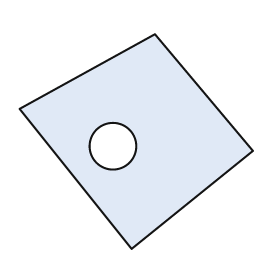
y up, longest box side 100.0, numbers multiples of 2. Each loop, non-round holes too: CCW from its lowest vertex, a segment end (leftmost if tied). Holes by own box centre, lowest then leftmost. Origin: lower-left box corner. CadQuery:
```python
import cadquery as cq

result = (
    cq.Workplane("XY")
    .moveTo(48.0, 0.0)
    .lineTo(100.0, 42.0)
    .lineTo(58.0, 92.0)
    .lineTo(0.0, 60.0)
    .close()
    .moveTo(40.0, 44.0)
    .circle(10.0)
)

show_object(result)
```